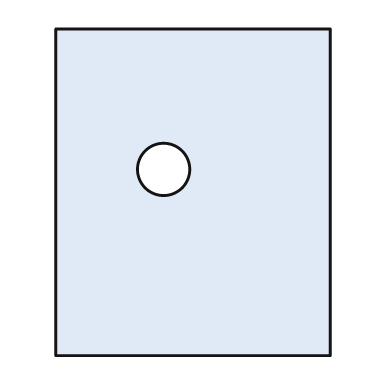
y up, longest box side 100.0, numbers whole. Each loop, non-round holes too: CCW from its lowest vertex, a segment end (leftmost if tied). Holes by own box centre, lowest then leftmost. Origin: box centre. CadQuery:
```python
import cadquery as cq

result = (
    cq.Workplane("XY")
    .moveTo(-42.0, -50.0)
    .lineTo(42.0, -50.0)
    .lineTo(42.0, 50.0)
    .lineTo(-42.0, 50.0)
    .close()
    .moveTo(-9.0, 7.0)
    .circle(8.0)
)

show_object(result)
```